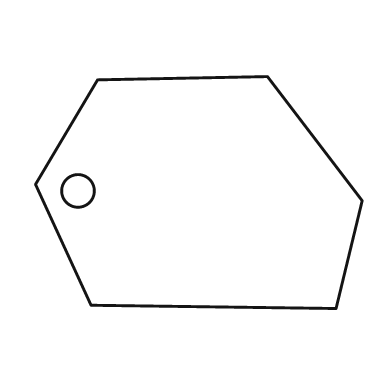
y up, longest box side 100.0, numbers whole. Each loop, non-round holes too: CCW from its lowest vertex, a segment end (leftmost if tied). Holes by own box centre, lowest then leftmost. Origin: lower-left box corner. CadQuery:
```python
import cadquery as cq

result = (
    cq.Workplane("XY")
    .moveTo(92.0, 0.0)
    .lineTo(100.0, 33.0)
    .lineTo(71.0, 71.0)
    .lineTo(19.0, 70.0)
    .lineTo(0.0, 38.0)
    .lineTo(17.0, 1.0)
    .close()
    .moveTo(13.0, 36.0)
    .circle(5.0)
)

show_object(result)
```